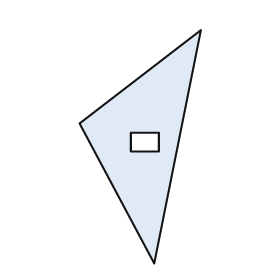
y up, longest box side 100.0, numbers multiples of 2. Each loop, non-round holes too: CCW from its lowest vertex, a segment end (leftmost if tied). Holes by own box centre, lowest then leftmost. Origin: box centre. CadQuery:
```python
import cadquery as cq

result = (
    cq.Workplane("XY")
    .moveTo(6.0, -50.0)
    .lineTo(26.0, 50.0)
    .lineTo(-26.0, 10.0)
    .close()
    .moveTo(-4.0, -2.0)
    .lineTo(8.0, -2.0)
    .lineTo(8.0, 6.0)
    .lineTo(-4.0, 6.0)
    .close()
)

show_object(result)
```